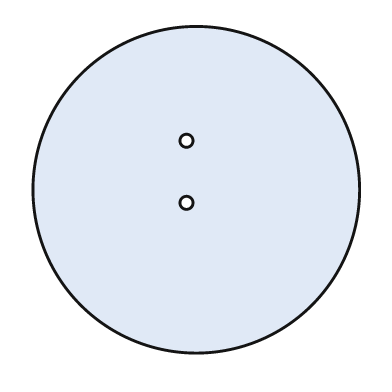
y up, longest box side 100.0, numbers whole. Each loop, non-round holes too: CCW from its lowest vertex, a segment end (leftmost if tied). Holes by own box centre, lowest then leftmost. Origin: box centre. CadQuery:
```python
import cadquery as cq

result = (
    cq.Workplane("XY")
    .moveTo(0.0, 0.0)
    .circle(50.0)
    .moveTo(-3.0, -4.0)
    .circle(2.0)
    .moveTo(-3.0, 15.0)
    .circle(2.0)
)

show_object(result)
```